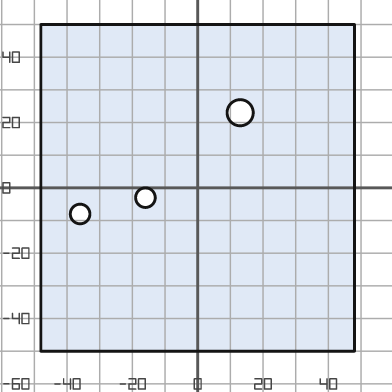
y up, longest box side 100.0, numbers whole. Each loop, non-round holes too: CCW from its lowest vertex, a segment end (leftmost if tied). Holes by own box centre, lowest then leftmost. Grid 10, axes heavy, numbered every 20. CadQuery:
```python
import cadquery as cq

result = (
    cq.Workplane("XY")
    .moveTo(-48.0, -50.0)
    .lineTo(48.0, -50.0)
    .lineTo(48.0, 50.0)
    .lineTo(-48.0, 50.0)
    .close()
    .moveTo(-36.0, -8.0)
    .circle(3.0)
    .moveTo(-16.0, -3.0)
    .circle(3.0)
    .moveTo(13.0, 23.0)
    .circle(4.0)
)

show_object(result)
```